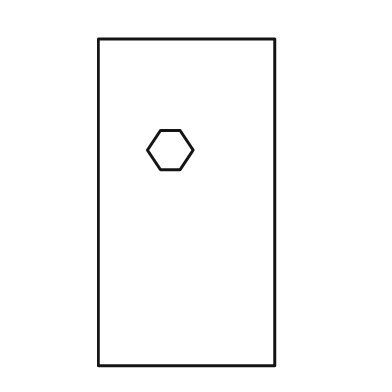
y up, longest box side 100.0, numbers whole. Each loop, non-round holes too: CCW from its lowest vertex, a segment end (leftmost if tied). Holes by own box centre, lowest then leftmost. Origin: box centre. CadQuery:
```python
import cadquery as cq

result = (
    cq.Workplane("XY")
    .moveTo(-27.0, -50.0)
    .lineTo(27.0, -50.0)
    .lineTo(27.0, 50.0)
    .lineTo(-27.0, 50.0)
    .close()
    .moveTo(-8.0, 10.0)
    .lineTo(-2.0, 10.0)
    .lineTo(2.0, 16.0)
    .lineTo(-2.0, 22.0)
    .lineTo(-8.0, 22.0)
    .lineTo(-12.0, 16.0)
    .close()
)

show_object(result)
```